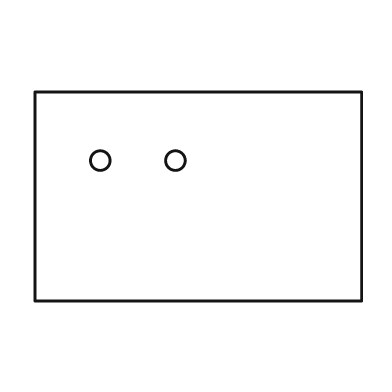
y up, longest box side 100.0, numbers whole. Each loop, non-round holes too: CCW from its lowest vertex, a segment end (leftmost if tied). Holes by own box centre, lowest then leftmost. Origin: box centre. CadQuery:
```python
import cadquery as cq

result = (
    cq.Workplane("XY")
    .moveTo(-50.0, -32.0)
    .lineTo(50.0, -32.0)
    .lineTo(50.0, 32.0)
    .lineTo(-50.0, 32.0)
    .close()
    .moveTo(-30.0, 11.0)
    .circle(3.0)
    .moveTo(-7.0, 11.0)
    .circle(3.0)
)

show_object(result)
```